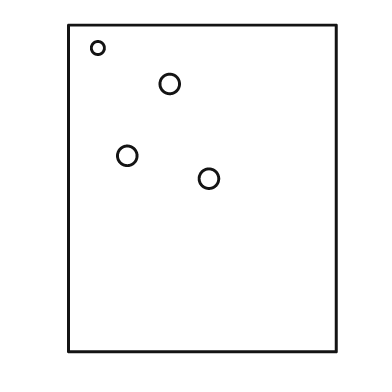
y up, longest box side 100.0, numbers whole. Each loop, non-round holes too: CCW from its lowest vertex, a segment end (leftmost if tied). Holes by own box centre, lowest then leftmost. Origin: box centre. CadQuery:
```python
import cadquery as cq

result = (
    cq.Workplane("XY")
    .moveTo(-41.0, -50.0)
    .lineTo(41.0, -50.0)
    .lineTo(41.0, 50.0)
    .lineTo(-41.0, 50.0)
    .close()
    .moveTo(2.0, 3.0)
    .circle(3.0)
    .moveTo(-23.0, 10.0)
    .circle(3.0)
    .moveTo(-10.0, 32.0)
    .circle(3.0)
    .moveTo(-32.0, 43.0)
    .circle(2.0)
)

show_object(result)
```